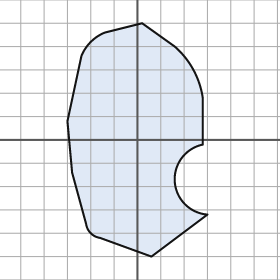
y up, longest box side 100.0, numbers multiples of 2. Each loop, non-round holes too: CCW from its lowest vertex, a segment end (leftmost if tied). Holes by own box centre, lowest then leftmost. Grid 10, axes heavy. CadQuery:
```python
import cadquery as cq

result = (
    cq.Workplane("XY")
    .moveTo(6.0, -50.0)
    .lineTo(30.0, -32.0)
    .threePointArc((16.0, -18.0), (28.0, -2.0))
    .lineTo(28.0, 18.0)
    .threePointArc((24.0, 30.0), (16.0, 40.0))
    .lineTo(2.0, 50.0)
    .lineTo(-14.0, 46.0)
    .threePointArc((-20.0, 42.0), (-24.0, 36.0))
    .lineTo(-30.0, 8.0)
    .lineTo(-28.0, -14.0)
    .lineTo(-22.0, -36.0)
    .threePointArc((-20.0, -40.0), (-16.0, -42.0))
    .close()
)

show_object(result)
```